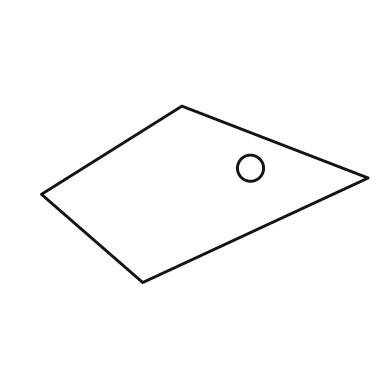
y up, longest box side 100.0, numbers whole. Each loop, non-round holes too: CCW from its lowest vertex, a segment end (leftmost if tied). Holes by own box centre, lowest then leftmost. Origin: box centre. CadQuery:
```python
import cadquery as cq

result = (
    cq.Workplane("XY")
    .moveTo(-19.0, -27.0)
    .lineTo(50.0, 5.0)
    .lineTo(-7.0, 27.0)
    .lineTo(-50.0, 0.0)
    .close()
    .moveTo(14.0, 8.0)
    .circle(4.0)
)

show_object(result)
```